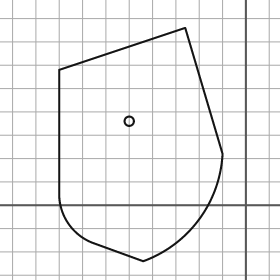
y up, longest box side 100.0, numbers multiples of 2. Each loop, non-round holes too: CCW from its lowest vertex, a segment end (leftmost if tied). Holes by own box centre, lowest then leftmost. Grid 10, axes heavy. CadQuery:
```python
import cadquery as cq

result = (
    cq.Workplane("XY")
    .moveTo(-44.0, -24.0)
    .threePointArc((-20.0, -6.0), (-10.0, 22.0))
    .lineTo(-26.0, 76.0)
    .lineTo(-80.0, 58.0)
    .lineTo(-80.0, 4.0)
    .threePointArc((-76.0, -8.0), (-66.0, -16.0))
    .close()
    .moveTo(-50.0, 36.0)
    .circle(2.0)
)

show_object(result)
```